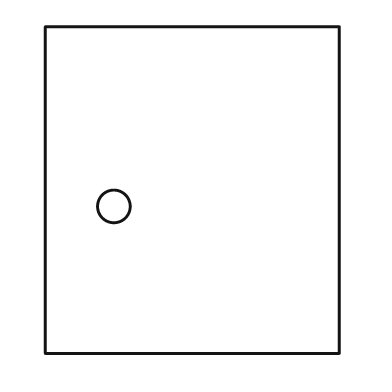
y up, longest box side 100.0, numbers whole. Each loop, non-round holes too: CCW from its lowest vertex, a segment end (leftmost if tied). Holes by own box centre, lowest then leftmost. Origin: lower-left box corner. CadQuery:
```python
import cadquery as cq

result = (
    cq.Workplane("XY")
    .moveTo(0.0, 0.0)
    .lineTo(90.0, 0.0)
    .lineTo(90.0, 100.0)
    .lineTo(0.0, 100.0)
    .close()
    .moveTo(21.0, 45.0)
    .circle(5.0)
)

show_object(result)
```